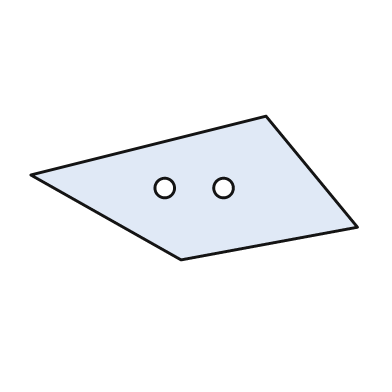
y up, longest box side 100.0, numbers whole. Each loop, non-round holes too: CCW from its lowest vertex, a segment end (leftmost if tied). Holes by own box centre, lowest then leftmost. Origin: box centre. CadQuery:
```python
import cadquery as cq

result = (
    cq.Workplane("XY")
    .moveTo(-4.0, -22.0)
    .lineTo(50.0, -12.0)
    .lineTo(22.0, 22.0)
    .lineTo(-50.0, 4.0)
    .close()
    .moveTo(-9.0, 0.0)
    .circle(3.0)
    .moveTo(9.0, 0.0)
    .circle(3.0)
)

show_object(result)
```